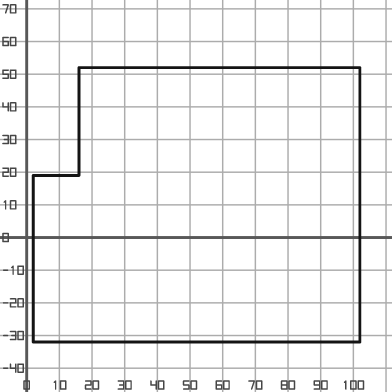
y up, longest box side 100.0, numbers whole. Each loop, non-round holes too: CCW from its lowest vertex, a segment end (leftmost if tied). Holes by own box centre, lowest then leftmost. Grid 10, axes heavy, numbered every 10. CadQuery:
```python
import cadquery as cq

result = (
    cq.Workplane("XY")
    .moveTo(2.0, -32.0)
    .lineTo(102.0, -32.0)
    .lineTo(102.0, 52.0)
    .lineTo(16.0, 52.0)
    .lineTo(16.0, 19.0)
    .lineTo(2.0, 19.0)
    .close()
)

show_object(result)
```